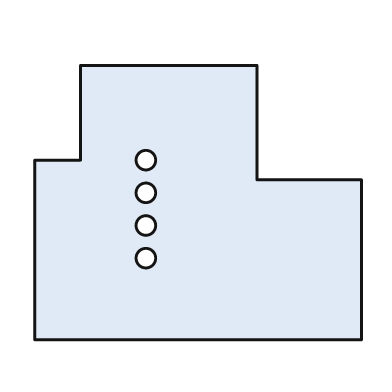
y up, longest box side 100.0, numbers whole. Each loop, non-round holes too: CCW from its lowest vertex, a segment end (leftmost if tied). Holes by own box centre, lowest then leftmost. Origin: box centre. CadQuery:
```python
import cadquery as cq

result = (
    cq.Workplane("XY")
    .moveTo(-50.0, -42.0)
    .lineTo(50.0, -42.0)
    .lineTo(50.0, 7.0)
    .lineTo(18.0, 7.0)
    .lineTo(18.0, 42.0)
    .lineTo(-36.0, 42.0)
    .lineTo(-36.0, 13.0)
    .lineTo(-50.0, 13.0)
    .close()
    .moveTo(-16.0, -17.0)
    .circle(3.0)
    .moveTo(-16.0, -7.0)
    .circle(3.0)
    .moveTo(-16.0, 3.0)
    .circle(3.0)
    .moveTo(-16.0, 13.0)
    .circle(3.0)
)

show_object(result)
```